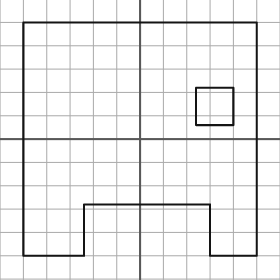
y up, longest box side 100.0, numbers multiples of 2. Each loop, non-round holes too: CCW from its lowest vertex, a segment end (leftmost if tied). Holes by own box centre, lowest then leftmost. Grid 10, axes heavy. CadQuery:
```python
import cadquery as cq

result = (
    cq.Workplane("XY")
    .moveTo(-50.0, -50.0)
    .lineTo(-24.0, -50.0)
    .lineTo(-24.0, -28.0)
    .lineTo(30.0, -28.0)
    .lineTo(30.0, -50.0)
    .lineTo(50.0, -50.0)
    .lineTo(50.0, 50.0)
    .lineTo(-50.0, 50.0)
    .close()
    .moveTo(24.0, 6.0)
    .lineTo(40.0, 6.0)
    .lineTo(40.0, 22.0)
    .lineTo(24.0, 22.0)
    .close()
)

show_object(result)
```